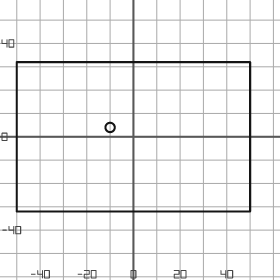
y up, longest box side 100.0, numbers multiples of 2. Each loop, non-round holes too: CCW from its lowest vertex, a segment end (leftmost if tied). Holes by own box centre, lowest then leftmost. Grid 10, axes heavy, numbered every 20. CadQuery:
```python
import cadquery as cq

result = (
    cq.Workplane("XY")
    .moveTo(-50.0, -32.0)
    .lineTo(50.0, -32.0)
    .lineTo(50.0, 32.0)
    .lineTo(-50.0, 32.0)
    .close()
    .moveTo(-10.0, 4.0)
    .circle(2.0)
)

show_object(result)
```